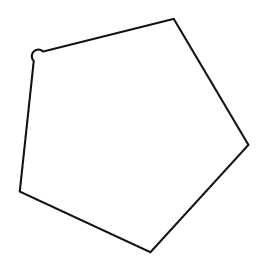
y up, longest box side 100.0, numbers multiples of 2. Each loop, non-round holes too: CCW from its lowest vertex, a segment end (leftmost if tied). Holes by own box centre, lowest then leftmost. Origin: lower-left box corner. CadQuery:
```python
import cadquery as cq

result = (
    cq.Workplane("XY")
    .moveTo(56.0, 0.0)
    .lineTo(98.0, 46.0)
    .lineTo(66.0, 100.0)
    .lineTo(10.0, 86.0)
    .threePointArc((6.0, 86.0), (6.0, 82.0))
    .lineTo(0.0, 26.0)
    .close()
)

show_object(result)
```